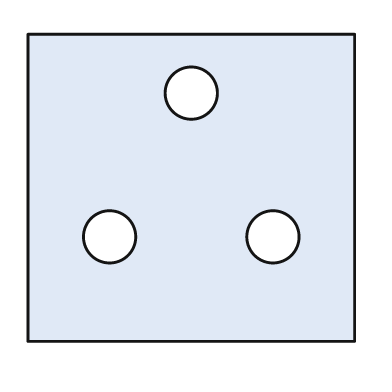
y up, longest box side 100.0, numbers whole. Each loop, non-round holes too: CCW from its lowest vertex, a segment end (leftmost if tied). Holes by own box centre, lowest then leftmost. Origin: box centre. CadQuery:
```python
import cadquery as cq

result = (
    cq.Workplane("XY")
    .moveTo(-50.0, -47.0)
    .lineTo(50.0, -47.0)
    .lineTo(50.0, 47.0)
    .lineTo(-50.0, 47.0)
    .close()
    .moveTo(-25.0, -15.0)
    .circle(8.0)
    .moveTo(25.0, -15.0)
    .circle(8.0)
    .moveTo(0.0, 29.0)
    .circle(8.0)
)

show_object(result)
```